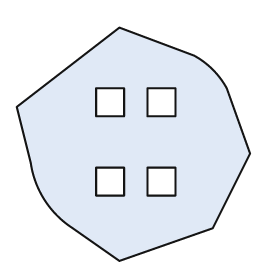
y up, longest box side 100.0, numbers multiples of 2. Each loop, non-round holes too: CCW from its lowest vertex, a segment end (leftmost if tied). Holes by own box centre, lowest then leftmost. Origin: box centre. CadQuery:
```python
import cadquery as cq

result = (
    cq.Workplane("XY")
    .moveTo(-6.0, -50.0)
    .lineTo(34.0, -36.0)
    .lineTo(50.0, -4.0)
    .lineTo(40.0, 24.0)
    .threePointArc((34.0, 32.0), (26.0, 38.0))
    .lineTo(-6.0, 50.0)
    .lineTo(-50.0, 16.0)
    .lineTo(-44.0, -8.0)
    .threePointArc((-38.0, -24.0), (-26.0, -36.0))
    .close()
    .moveTo(-16.0, -22.0)
    .lineTo(-4.0, -22.0)
    .lineTo(-4.0, -10.0)
    .lineTo(-16.0, -10.0)
    .close()
    .moveTo(6.0, -22.0)
    .lineTo(18.0, -22.0)
    .lineTo(18.0, -10.0)
    .lineTo(6.0, -10.0)
    .close()
    .moveTo(-16.0, 12.0)
    .lineTo(-4.0, 12.0)
    .lineTo(-4.0, 24.0)
    .lineTo(-16.0, 24.0)
    .close()
    .moveTo(6.0, 12.0)
    .lineTo(18.0, 12.0)
    .lineTo(18.0, 24.0)
    .lineTo(6.0, 24.0)
    .close()
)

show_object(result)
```